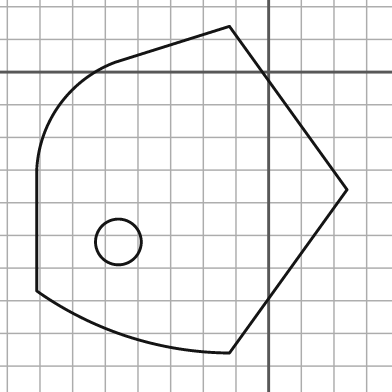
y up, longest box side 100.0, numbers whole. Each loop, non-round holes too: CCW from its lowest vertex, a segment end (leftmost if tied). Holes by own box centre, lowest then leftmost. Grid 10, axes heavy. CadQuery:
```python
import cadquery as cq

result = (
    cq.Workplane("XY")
    .moveTo(-12.0, -86.0)
    .lineTo(24.0, -36.0)
    .lineTo(-12.0, 14.0)
    .lineTo(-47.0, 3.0)
    .threePointArc((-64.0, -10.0), (-71.0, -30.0))
    .lineTo(-71.0, -67.0)
    .threePointArc((-43.0, -81.0), (-12.0, -86.0))
    .close()
    .moveTo(-46.0, -52.0)
    .circle(7.0)
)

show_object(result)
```